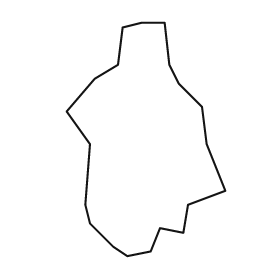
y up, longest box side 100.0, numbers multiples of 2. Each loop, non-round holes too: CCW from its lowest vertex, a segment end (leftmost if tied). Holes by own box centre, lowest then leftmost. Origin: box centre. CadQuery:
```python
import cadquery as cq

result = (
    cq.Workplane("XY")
    .moveTo(-8.0, -50.0)
    .lineTo(2.0, -48.0)
    .lineTo(6.0, -38.0)
    .lineTo(16.0, -40.0)
    .lineTo(18.0, -28.0)
    .lineTo(34.0, -22.0)
    .lineTo(26.0, -2.0)
    .lineTo(24.0, 14.0)
    .lineTo(14.0, 24.0)
    .lineTo(10.0, 32.0)
    .lineTo(8.0, 50.0)
    .lineTo(-2.0, 50.0)
    .lineTo(-10.0, 48.0)
    .lineTo(-12.0, 32.0)
    .lineTo(-22.0, 26.0)
    .lineTo(-34.0, 12.0)
    .lineTo(-24.0, -2.0)
    .lineTo(-26.0, -28.0)
    .lineTo(-24.0, -36.0)
    .lineTo(-14.0, -46.0)
    .close()
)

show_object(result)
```